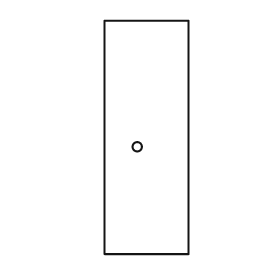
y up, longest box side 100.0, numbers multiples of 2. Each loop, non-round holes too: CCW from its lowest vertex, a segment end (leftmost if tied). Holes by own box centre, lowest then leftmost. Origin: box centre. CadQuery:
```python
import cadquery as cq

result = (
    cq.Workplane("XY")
    .moveTo(-18.0, -50.0)
    .lineTo(18.0, -50.0)
    .lineTo(18.0, 50.0)
    .lineTo(-18.0, 50.0)
    .close()
    .moveTo(-4.0, -4.0)
    .circle(2.0)
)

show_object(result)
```